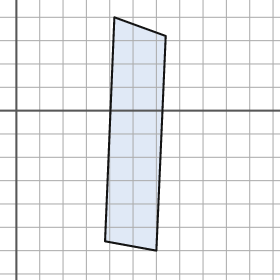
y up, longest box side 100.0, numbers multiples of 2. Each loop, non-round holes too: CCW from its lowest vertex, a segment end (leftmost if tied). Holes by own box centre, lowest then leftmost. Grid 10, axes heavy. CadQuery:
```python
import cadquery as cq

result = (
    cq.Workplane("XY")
    .moveTo(60.0, -60.0)
    .lineTo(64.0, 32.0)
    .lineTo(42.0, 40.0)
    .lineTo(38.0, -56.0)
    .close()
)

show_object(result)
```